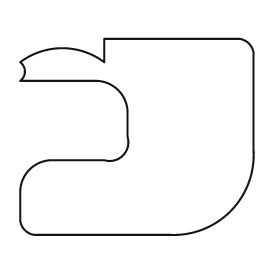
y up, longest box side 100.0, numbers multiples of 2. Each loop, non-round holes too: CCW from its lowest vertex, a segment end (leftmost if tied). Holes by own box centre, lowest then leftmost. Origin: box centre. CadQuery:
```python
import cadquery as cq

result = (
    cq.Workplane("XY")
    .moveTo(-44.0, -42.0)
    .lineTo(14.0, -42.0)
    .threePointArc((40.0, -32.0), (50.0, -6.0))
    .lineTo(50.0, 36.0)
    .threePointArc((48.0, 40.0), (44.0, 42.0))
    .lineTo(-14.0, 42.0)
    .lineTo(-14.0, 32.0)
    .threePointArc((-32.0, 38.0), (-50.0, 32.0))
    .threePointArc((-48.0, 28.0), (-50.0, 24.0))
    .lineTo(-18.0, 24.0)
    .threePointArc((-8.0, 20.0), (-4.0, 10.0))
    .lineTo(-4.0, 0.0)
    .threePointArc((-6.0, -8.0), (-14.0, -10.0))
    .lineTo(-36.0, -10.0)
    .threePointArc((-46.0, -14.0), (-50.0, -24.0))
    .lineTo(-50.0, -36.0)
    .threePointArc((-48.0, -40.0), (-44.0, -42.0))
    .close()
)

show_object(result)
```